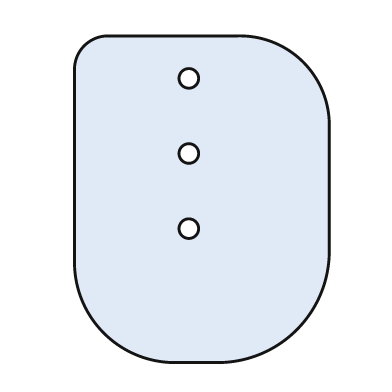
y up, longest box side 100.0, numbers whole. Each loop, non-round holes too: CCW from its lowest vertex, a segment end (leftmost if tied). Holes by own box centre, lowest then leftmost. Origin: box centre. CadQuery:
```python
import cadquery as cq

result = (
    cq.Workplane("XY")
    .moveTo(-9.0, -50.0)
    .lineTo(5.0, -50.0)
    .threePointArc((29.0, -40.0), (39.0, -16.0))
    .lineTo(39.0, 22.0)
    .threePointArc((31.0, 42.0), (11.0, 50.0))
    .lineTo(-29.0, 50.0)
    .threePointArc((-36.0, 47.0), (-39.0, 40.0))
    .lineTo(-39.0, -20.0)
    .threePointArc((-30.0, -41.0), (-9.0, -50.0))
    .close()
    .moveTo(-4.0, -9.0)
    .circle(3.0)
    .moveTo(-4.0, 14.0)
    .circle(3.0)
    .moveTo(-4.0, 37.0)
    .circle(3.0)
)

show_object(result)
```